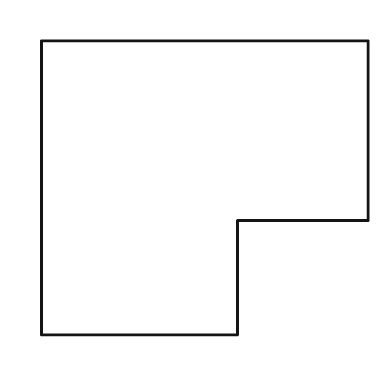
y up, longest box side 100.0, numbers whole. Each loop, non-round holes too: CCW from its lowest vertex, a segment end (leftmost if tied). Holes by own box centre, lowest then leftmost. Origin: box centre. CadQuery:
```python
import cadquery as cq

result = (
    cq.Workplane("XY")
    .moveTo(-50.0, -45.0)
    .lineTo(10.0, -45.0)
    .lineTo(10.0, -10.0)
    .lineTo(50.0, -10.0)
    .lineTo(50.0, 45.0)
    .lineTo(-50.0, 45.0)
    .close()
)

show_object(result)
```